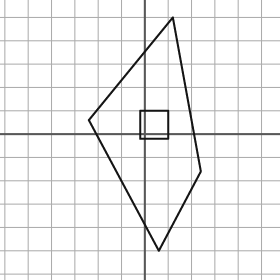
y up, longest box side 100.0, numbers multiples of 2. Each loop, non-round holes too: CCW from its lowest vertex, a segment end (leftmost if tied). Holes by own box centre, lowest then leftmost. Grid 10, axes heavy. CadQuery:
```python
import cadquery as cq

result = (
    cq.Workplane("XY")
    .moveTo(6.0, -50.0)
    .lineTo(24.0, -16.0)
    .lineTo(12.0, 50.0)
    .lineTo(-24.0, 6.0)
    .close()
    .moveTo(-2.0, -2.0)
    .lineTo(10.0, -2.0)
    .lineTo(10.0, 10.0)
    .lineTo(-2.0, 10.0)
    .close()
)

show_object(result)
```